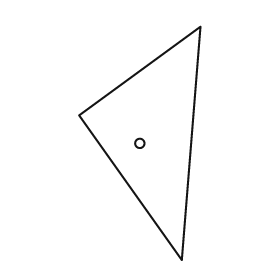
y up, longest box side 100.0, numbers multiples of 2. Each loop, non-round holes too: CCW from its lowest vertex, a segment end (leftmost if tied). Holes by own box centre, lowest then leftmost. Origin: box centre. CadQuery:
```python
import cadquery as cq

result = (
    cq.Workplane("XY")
    .moveTo(18.0, -50.0)
    .lineTo(26.0, 50.0)
    .lineTo(-26.0, 12.0)
    .close()
    .moveTo(0.0, 0.0)
    .circle(2.0)
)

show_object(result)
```